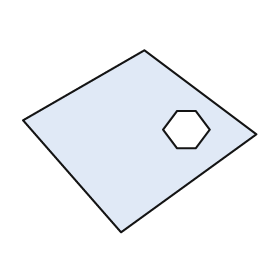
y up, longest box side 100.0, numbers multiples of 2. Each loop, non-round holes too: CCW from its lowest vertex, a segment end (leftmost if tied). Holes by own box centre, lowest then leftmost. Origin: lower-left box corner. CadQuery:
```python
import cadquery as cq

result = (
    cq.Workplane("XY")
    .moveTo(42.0, 0.0)
    .lineTo(100.0, 42.0)
    .lineTo(52.0, 78.0)
    .lineTo(0.0, 48.0)
    .close()
    .moveTo(66.0, 36.0)
    .lineTo(74.0, 36.0)
    .lineTo(80.0, 44.0)
    .lineTo(74.0, 52.0)
    .lineTo(66.0, 52.0)
    .lineTo(60.0, 44.0)
    .close()
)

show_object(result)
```